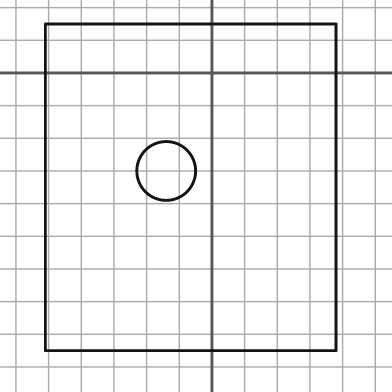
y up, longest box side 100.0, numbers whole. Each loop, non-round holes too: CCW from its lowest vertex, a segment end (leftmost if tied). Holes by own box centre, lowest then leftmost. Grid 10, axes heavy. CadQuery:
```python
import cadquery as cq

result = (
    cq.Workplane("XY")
    .moveTo(-51.0, -85.0)
    .lineTo(38.0, -85.0)
    .lineTo(38.0, 15.0)
    .lineTo(-51.0, 15.0)
    .close()
    .moveTo(-14.0, -30.0)
    .circle(9.0)
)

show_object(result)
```